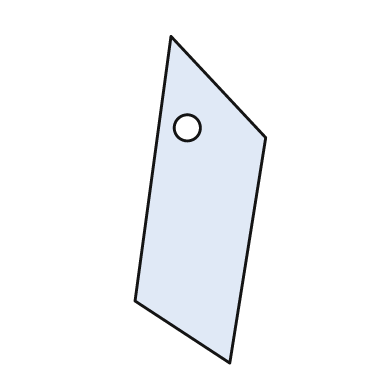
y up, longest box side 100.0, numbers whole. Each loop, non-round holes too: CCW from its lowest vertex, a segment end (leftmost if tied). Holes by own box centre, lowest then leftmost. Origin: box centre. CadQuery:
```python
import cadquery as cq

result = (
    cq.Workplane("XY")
    .moveTo(9.0, -50.0)
    .lineTo(20.0, 19.0)
    .lineTo(-9.0, 50.0)
    .lineTo(-20.0, -31.0)
    .close()
    .moveTo(-4.0, 22.0)
    .circle(4.0)
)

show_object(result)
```